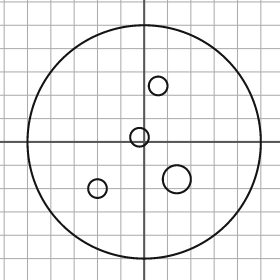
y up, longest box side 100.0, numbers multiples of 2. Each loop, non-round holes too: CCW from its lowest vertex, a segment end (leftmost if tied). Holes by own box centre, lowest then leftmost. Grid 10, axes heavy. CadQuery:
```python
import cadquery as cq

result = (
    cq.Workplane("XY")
    .moveTo(0.0, 0.0)
    .circle(50.0)
    .moveTo(-20.0, -20.0)
    .circle(4.0)
    .moveTo(14.0, -16.0)
    .circle(6.0)
    .moveTo(-2.0, 2.0)
    .circle(4.0)
    .moveTo(6.0, 24.0)
    .circle(4.0)
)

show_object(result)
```